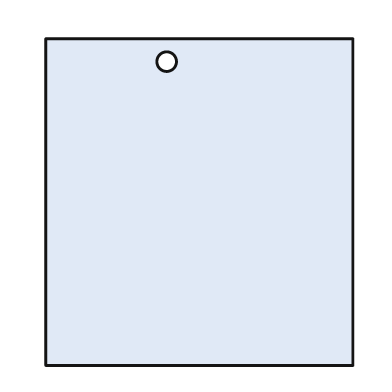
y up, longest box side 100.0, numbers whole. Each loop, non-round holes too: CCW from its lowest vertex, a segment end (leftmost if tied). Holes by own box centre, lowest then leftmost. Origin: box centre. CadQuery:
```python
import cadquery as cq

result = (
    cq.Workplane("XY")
    .moveTo(-47.0, -50.0)
    .lineTo(47.0, -50.0)
    .lineTo(47.0, 50.0)
    .lineTo(-47.0, 50.0)
    .close()
    .moveTo(-10.0, 43.0)
    .circle(3.0)
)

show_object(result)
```